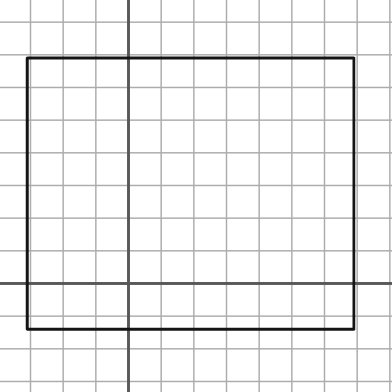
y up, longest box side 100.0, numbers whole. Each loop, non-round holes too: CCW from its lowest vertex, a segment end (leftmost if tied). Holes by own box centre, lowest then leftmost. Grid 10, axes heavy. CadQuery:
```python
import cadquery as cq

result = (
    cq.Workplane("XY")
    .moveTo(-31.0, -14.0)
    .lineTo(69.0, -14.0)
    .lineTo(69.0, 69.0)
    .lineTo(-31.0, 69.0)
    .close()
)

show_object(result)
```